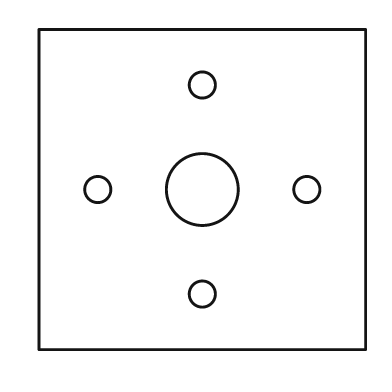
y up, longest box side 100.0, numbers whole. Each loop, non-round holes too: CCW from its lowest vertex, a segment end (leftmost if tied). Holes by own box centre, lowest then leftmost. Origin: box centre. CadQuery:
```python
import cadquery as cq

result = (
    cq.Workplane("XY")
    .moveTo(-50.0, -49.0)
    .lineTo(50.0, -49.0)
    .lineTo(50.0, 49.0)
    .lineTo(-50.0, 49.0)
    .close()
    .moveTo(0.0, -32.0)
    .circle(4.0)
    .moveTo(-32.0, 0.0)
    .circle(4.0)
    .moveTo(0.0, 0.0)
    .circle(11.0)
    .moveTo(32.0, 0.0)
    .circle(4.0)
    .moveTo(0.0, 32.0)
    .circle(4.0)
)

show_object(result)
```